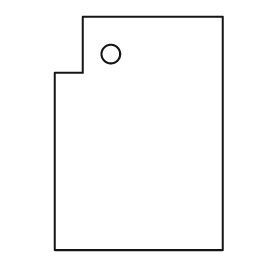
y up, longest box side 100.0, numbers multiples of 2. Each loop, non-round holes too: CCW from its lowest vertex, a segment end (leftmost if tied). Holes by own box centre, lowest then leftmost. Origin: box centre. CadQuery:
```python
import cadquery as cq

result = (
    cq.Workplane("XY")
    .moveTo(-36.0, -50.0)
    .lineTo(36.0, -50.0)
    .lineTo(36.0, 50.0)
    .lineTo(-24.0, 50.0)
    .lineTo(-24.0, 26.0)
    .lineTo(-36.0, 26.0)
    .close()
    .moveTo(-12.0, 34.0)
    .circle(4.0)
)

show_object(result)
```